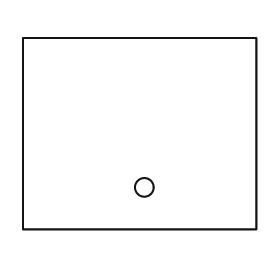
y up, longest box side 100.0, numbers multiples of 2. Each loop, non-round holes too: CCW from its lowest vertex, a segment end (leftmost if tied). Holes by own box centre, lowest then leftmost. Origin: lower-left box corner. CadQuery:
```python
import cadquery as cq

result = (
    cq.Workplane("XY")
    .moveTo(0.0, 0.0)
    .lineTo(100.0, 0.0)
    .lineTo(100.0, 82.0)
    .lineTo(0.0, 82.0)
    .close()
    .moveTo(52.0, 18.0)
    .circle(4.0)
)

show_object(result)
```